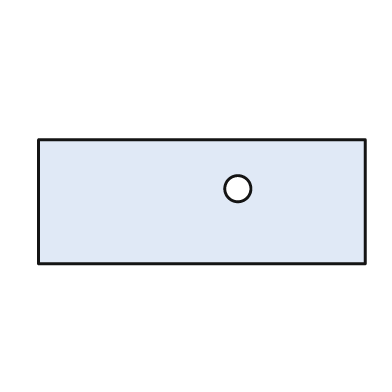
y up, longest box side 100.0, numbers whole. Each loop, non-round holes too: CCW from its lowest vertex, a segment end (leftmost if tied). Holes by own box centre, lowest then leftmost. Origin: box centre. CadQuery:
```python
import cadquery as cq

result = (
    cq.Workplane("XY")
    .moveTo(-50.0, -19.0)
    .lineTo(50.0, -19.0)
    .lineTo(50.0, 19.0)
    .lineTo(-50.0, 19.0)
    .close()
    .moveTo(11.0, 4.0)
    .circle(4.0)
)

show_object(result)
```